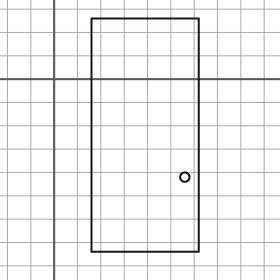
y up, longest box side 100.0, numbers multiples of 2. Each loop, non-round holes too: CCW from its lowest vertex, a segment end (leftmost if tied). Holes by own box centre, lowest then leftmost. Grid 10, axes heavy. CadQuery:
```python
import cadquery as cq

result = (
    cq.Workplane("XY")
    .moveTo(16.0, -74.0)
    .lineTo(62.0, -74.0)
    .lineTo(62.0, 26.0)
    .lineTo(16.0, 26.0)
    .close()
    .moveTo(56.0, -42.0)
    .circle(2.0)
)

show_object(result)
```